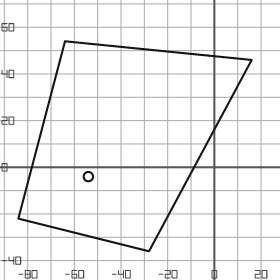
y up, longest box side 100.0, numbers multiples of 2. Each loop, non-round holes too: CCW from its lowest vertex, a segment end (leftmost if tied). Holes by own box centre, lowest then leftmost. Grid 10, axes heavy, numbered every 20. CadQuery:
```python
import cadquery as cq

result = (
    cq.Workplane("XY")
    .moveTo(-28.0, -36.0)
    .lineTo(16.0, 46.0)
    .lineTo(-64.0, 54.0)
    .lineTo(-84.0, -22.0)
    .close()
    .moveTo(-54.0, -4.0)
    .circle(2.0)
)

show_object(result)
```